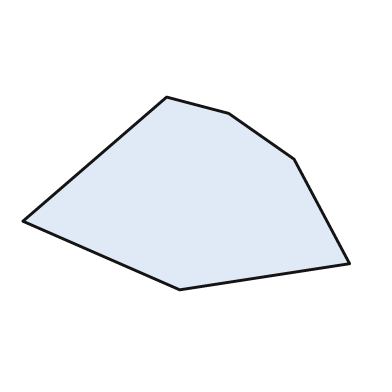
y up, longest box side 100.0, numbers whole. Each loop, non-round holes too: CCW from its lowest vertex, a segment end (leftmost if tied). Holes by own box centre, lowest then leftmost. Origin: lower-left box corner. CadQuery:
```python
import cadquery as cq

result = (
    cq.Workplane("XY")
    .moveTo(48.0, 0.0)
    .lineTo(100.0, 8.0)
    .lineTo(83.0, 40.0)
    .lineTo(63.0, 54.0)
    .lineTo(44.0, 59.0)
    .lineTo(0.0, 21.0)
    .close()
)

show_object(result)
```